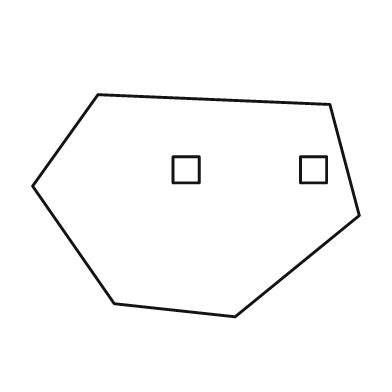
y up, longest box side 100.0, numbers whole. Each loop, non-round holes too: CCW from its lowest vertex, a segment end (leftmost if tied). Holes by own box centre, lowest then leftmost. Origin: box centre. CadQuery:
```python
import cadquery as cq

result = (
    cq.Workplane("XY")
    .moveTo(12.0, -34.0)
    .lineTo(50.0, -3.0)
    .lineTo(41.0, 31.0)
    .lineTo(-30.0, 34.0)
    .lineTo(-50.0, 6.0)
    .lineTo(-25.0, -30.0)
    .close()
    .moveTo(-7.0, 7.0)
    .lineTo(1.0, 7.0)
    .lineTo(1.0, 15.0)
    .lineTo(-7.0, 15.0)
    .close()
    .moveTo(32.0, 7.0)
    .lineTo(40.0, 7.0)
    .lineTo(40.0, 15.0)
    .lineTo(32.0, 15.0)
    .close()
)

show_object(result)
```